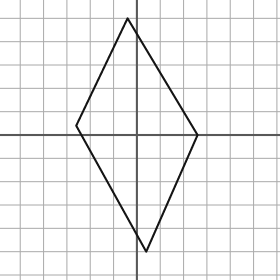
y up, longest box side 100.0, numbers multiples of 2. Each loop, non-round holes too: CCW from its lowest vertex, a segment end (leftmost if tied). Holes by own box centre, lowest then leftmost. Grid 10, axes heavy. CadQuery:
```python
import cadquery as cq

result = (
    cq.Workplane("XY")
    .moveTo(4.0, -50.0)
    .lineTo(26.0, 0.0)
    .lineTo(-4.0, 50.0)
    .lineTo(-26.0, 4.0)
    .close()
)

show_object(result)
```